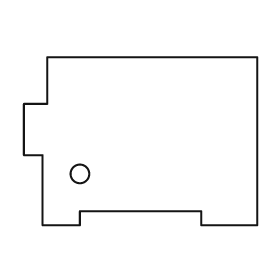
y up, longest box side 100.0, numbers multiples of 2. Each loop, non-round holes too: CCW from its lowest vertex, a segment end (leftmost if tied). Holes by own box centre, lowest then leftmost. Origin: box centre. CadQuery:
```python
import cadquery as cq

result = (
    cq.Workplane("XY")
    .moveTo(-42.0, -36.0)
    .lineTo(-26.0, -36.0)
    .lineTo(-26.0, -30.0)
    .lineTo(26.0, -30.0)
    .lineTo(26.0, -36.0)
    .lineTo(50.0, -36.0)
    .lineTo(50.0, 36.0)
    .lineTo(-40.0, 36.0)
    .lineTo(-40.0, 16.0)
    .lineTo(-50.0, 16.0)
    .lineTo(-50.0, -6.0)
    .lineTo(-42.0, -6.0)
    .close()
    .moveTo(-26.0, -14.0)
    .circle(4.0)
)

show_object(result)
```